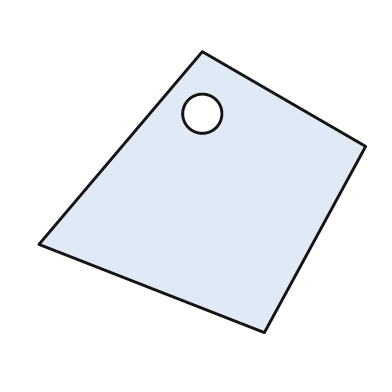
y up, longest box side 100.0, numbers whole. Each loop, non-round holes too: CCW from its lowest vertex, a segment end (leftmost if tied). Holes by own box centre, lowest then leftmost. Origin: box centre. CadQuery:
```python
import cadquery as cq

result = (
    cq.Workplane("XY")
    .moveTo(19.0, -43.0)
    .lineTo(50.0, 14.0)
    .lineTo(0.0, 43.0)
    .lineTo(-50.0, -16.0)
    .close()
    .moveTo(0.0, 24.0)
    .circle(6.0)
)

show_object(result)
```